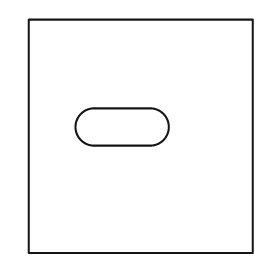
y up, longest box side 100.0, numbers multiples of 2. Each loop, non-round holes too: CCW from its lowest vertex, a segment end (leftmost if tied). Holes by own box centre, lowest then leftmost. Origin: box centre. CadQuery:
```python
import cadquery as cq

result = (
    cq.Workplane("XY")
    .moveTo(-48.0, -50.0)
    .lineTo(48.0, -50.0)
    .lineTo(48.0, 50.0)
    .lineTo(-48.0, 50.0)
    .close()
    .moveTo(-20.0, -4.0)
    .lineTo(4.0, -4.0)
    .threePointArc((12.0, 4.0), (4.0, 12.0))
    .lineTo(-20.0, 12.0)
    .threePointArc((-28.0, 4.0), (-20.0, -4.0))
    .close()
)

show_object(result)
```